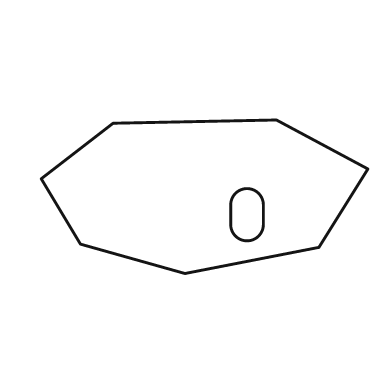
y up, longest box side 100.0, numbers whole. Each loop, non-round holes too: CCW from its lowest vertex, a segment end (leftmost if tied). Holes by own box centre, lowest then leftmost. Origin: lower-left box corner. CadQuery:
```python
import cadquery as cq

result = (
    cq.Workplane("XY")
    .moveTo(44.0, 0.0)
    .lineTo(85.0, 8.0)
    .lineTo(100.0, 32.0)
    .lineTo(72.0, 47.0)
    .lineTo(22.0, 46.0)
    .lineTo(0.0, 29.0)
    .lineTo(12.0, 9.0)
    .close()
    .moveTo(58.0, 15.0)
    .threePointArc((63.0, 10.0), (68.0, 15.0))
    .lineTo(68.0, 21.0)
    .threePointArc((63.0, 26.0), (58.0, 21.0))
    .close()
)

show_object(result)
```